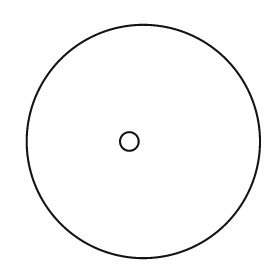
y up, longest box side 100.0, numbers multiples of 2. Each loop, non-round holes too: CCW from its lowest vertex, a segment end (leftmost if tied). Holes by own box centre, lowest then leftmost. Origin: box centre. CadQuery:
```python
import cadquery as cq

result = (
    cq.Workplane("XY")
    .moveTo(0.0, 0.0)
    .circle(50.0)
    .moveTo(-6.0, 0.0)
    .circle(4.0)
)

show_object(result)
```